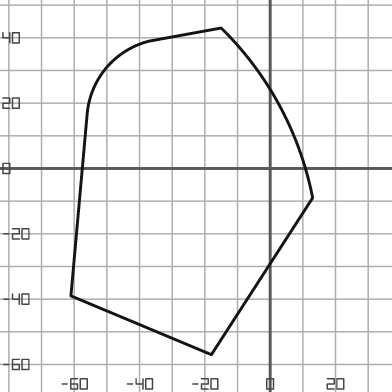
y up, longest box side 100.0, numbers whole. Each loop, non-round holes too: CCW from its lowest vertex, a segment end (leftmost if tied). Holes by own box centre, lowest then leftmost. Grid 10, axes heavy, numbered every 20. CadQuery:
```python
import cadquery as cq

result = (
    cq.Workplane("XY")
    .moveTo(-18.0, -57.0)
    .lineTo(13.0, -9.0)
    .threePointArc((3.0, 19.0), (-15.0, 43.0))
    .lineTo(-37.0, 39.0)
    .threePointArc((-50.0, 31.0), (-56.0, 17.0))
    .lineTo(-61.0, -39.0)
    .close()
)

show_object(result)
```